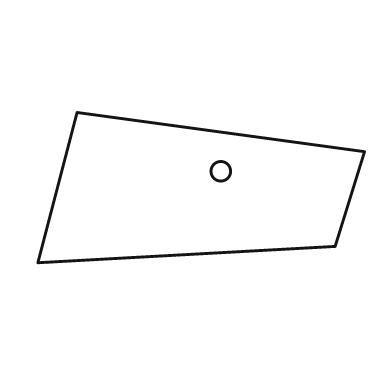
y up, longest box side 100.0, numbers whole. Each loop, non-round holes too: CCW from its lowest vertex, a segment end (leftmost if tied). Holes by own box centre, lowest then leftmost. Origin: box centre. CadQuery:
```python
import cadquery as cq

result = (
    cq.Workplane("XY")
    .moveTo(-50.0, -23.0)
    .lineTo(41.0, -18.0)
    .lineTo(50.0, 11.0)
    .lineTo(-38.0, 23.0)
    .close()
    .moveTo(6.0, 5.0)
    .circle(3.0)
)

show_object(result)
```